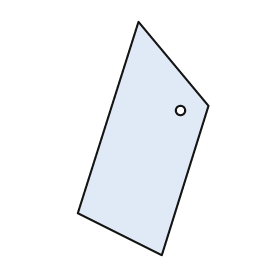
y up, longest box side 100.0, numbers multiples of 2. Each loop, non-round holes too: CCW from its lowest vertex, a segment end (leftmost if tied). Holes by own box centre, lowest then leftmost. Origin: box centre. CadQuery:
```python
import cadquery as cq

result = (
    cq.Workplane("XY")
    .moveTo(8.0, -50.0)
    .lineTo(28.0, 14.0)
    .lineTo(-2.0, 50.0)
    .lineTo(-28.0, -32.0)
    .close()
    .moveTo(16.0, 12.0)
    .circle(2.0)
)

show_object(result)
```